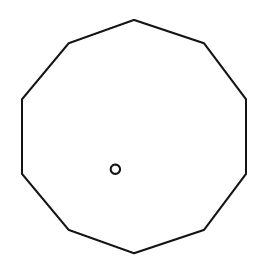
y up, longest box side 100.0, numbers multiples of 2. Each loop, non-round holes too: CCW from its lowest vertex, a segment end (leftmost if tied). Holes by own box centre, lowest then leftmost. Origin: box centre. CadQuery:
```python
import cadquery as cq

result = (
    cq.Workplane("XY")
    .moveTo(0.0, -50.0)
    .lineTo(30.0, -40.0)
    .lineTo(48.0, -16.0)
    .lineTo(48.0, 16.0)
    .lineTo(30.0, 40.0)
    .lineTo(0.0, 50.0)
    .lineTo(-28.0, 40.0)
    .lineTo(-48.0, 16.0)
    .lineTo(-48.0, -16.0)
    .lineTo(-28.0, -40.0)
    .close()
    .moveTo(-8.0, -14.0)
    .circle(2.0)
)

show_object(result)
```